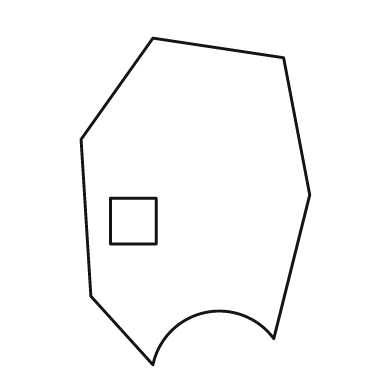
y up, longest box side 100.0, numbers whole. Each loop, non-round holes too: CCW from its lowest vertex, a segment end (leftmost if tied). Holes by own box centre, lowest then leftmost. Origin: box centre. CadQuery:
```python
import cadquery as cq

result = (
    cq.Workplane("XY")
    .moveTo(-13.0, -50.0)
    .threePointArc((3.0, -34.0), (24.0, -42.0))
    .lineTo(35.0, 2.0)
    .lineTo(27.0, 44.0)
    .lineTo(-13.0, 50.0)
    .lineTo(-35.0, 19.0)
    .lineTo(-32.0, -29.0)
    .close()
    .moveTo(-26.0, -13.0)
    .lineTo(-12.0, -13.0)
    .lineTo(-12.0, 1.0)
    .lineTo(-26.0, 1.0)
    .close()
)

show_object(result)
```